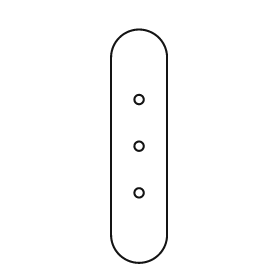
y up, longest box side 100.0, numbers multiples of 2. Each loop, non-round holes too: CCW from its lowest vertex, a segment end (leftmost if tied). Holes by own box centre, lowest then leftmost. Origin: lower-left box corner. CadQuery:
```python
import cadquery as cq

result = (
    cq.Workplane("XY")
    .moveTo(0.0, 12.0)
    .threePointArc((12.0, 0.0), (24.0, 12.0))
    .lineTo(24.0, 88.0)
    .threePointArc((12.0, 100.0), (0.0, 88.0))
    .close()
    .moveTo(12.0, 30.0)
    .circle(2.0)
    .moveTo(12.0, 50.0)
    .circle(2.0)
    .moveTo(12.0, 70.0)
    .circle(2.0)
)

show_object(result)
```